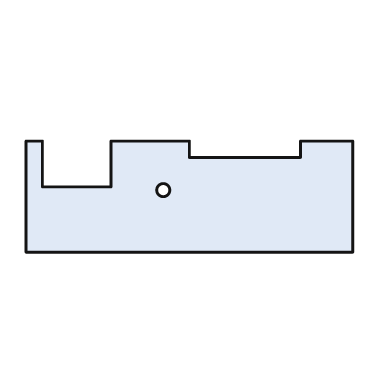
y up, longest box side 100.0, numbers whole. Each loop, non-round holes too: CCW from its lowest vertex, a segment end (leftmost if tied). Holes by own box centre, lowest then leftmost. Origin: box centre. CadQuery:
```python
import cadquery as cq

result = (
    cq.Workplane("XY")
    .moveTo(-50.0, -17.0)
    .lineTo(50.0, -17.0)
    .lineTo(50.0, 17.0)
    .lineTo(34.0, 17.0)
    .lineTo(34.0, 12.0)
    .lineTo(0.0, 12.0)
    .lineTo(0.0, 17.0)
    .lineTo(-24.0, 17.0)
    .lineTo(-24.0, 3.0)
    .lineTo(-45.0, 3.0)
    .lineTo(-45.0, 17.0)
    .lineTo(-50.0, 17.0)
    .close()
    .moveTo(-8.0, 2.0)
    .circle(2.0)
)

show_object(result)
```